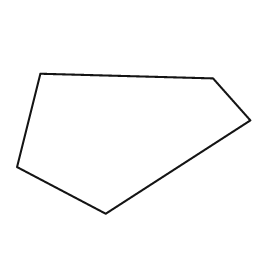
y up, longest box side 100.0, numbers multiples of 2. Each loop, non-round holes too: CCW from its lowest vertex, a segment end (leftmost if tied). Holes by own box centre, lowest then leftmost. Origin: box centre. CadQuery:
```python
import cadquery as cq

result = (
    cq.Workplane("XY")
    .moveTo(-12.0, -30.0)
    .lineTo(50.0, 10.0)
    .lineTo(34.0, 28.0)
    .lineTo(-40.0, 30.0)
    .lineTo(-50.0, -10.0)
    .close()
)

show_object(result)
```